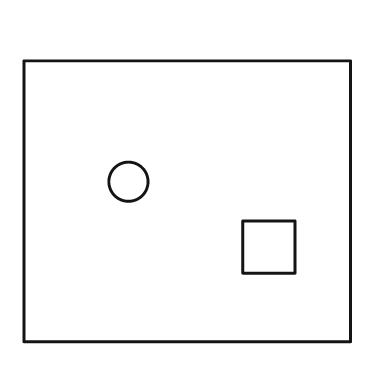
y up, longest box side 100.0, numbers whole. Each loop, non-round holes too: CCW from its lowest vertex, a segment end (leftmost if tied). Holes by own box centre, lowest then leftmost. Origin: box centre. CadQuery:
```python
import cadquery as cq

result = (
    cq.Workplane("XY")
    .moveTo(-50.0, -43.0)
    .lineTo(50.0, -43.0)
    .lineTo(50.0, 43.0)
    .lineTo(-50.0, 43.0)
    .close()
    .moveTo(17.0, -22.0)
    .lineTo(33.0, -22.0)
    .lineTo(33.0, -6.0)
    .lineTo(17.0, -6.0)
    .close()
    .moveTo(-18.0, 6.0)
    .circle(6.0)
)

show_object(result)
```